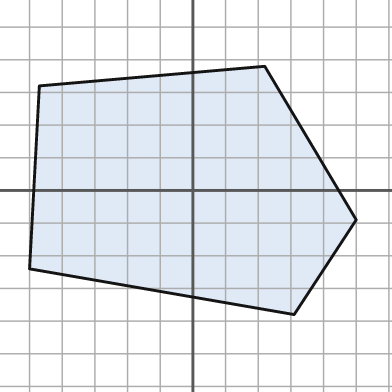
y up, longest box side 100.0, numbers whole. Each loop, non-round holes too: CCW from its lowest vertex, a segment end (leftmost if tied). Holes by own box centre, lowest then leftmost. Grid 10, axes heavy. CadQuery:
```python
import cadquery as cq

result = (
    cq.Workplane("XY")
    .moveTo(31.0, -38.0)
    .lineTo(50.0, -9.0)
    .lineTo(22.0, 38.0)
    .lineTo(-47.0, 32.0)
    .lineTo(-50.0, -24.0)
    .close()
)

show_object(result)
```